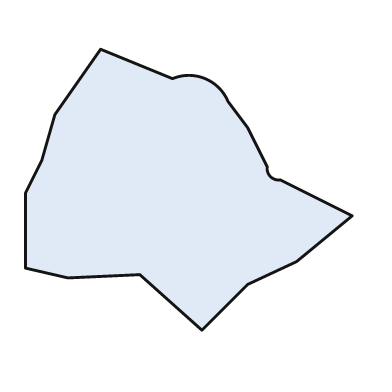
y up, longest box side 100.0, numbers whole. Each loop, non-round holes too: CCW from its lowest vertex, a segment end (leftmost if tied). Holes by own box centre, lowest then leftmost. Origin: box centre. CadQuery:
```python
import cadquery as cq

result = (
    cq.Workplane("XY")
    .moveTo(4.0, -43.0)
    .lineTo(18.0, -29.0)
    .lineTo(33.0, -22.0)
    .lineTo(50.0, -8.0)
    .lineTo(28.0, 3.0)
    .threePointArc((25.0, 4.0), (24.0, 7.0))
    .lineTo(18.0, 19.0)
    .lineTo(12.0, 27.0)
    .threePointArc((5.0, 34.0), (-5.0, 34.0))
    .lineTo(-27.0, 43.0)
    .lineTo(-41.0, 23.0)
    .lineTo(-45.0, 9.0)
    .lineTo(-50.0, -1.0)
    .lineTo(-50.0, -24.0)
    .lineTo(-37.0, -27.0)
    .lineTo(-15.0, -26.0)
    .close()
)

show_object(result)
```